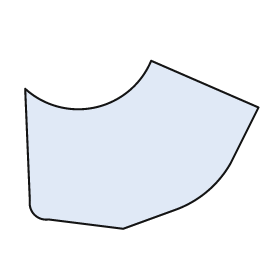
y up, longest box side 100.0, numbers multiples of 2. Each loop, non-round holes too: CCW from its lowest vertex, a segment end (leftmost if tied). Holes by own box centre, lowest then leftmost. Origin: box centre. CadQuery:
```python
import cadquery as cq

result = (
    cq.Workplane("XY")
    .moveTo(-8.0, -36.0)
    .lineTo(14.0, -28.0)
    .threePointArc((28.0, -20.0), (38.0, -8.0))
    .lineTo(50.0, 16.0)
    .lineTo(4.0, 36.0)
    .threePointArc((-20.0, 16.0), (-50.0, 24.0))
    .lineTo(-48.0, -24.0)
    .threePointArc((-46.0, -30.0), (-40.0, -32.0))
    .close()
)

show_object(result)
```